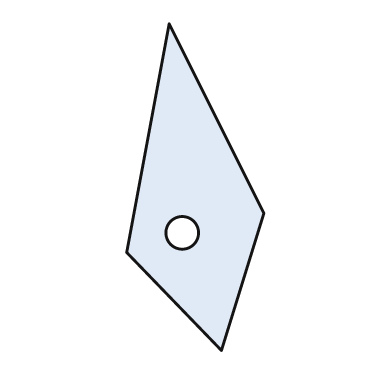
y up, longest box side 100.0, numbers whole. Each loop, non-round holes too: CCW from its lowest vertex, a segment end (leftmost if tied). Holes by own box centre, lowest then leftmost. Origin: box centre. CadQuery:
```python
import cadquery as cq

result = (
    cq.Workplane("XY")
    .moveTo(8.0, -50.0)
    .lineTo(21.0, -8.0)
    .lineTo(-8.0, 50.0)
    .lineTo(-21.0, -20.0)
    .close()
    .moveTo(-4.0, -14.0)
    .circle(5.0)
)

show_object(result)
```